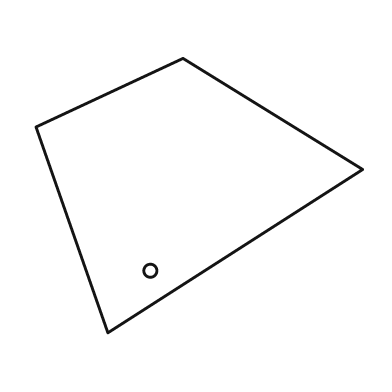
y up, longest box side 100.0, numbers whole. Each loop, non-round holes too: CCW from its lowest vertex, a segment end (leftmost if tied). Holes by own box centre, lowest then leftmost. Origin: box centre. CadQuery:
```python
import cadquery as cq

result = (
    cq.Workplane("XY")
    .moveTo(-28.0, -42.0)
    .lineTo(50.0, 8.0)
    .lineTo(-5.0, 42.0)
    .lineTo(-50.0, 21.0)
    .close()
    .moveTo(-15.0, -23.0)
    .circle(2.0)
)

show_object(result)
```